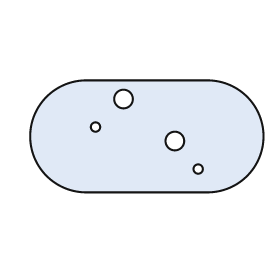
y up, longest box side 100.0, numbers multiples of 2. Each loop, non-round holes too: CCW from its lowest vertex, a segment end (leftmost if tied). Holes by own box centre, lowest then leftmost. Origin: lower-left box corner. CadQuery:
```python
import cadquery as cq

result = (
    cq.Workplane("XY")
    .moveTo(24.0, 0.0)
    .lineTo(76.0, 0.0)
    .threePointArc((100.0, 24.0), (76.0, 48.0))
    .lineTo(24.0, 48.0)
    .threePointArc((0.0, 24.0), (24.0, 0.0))
    .close()
    .moveTo(72.0, 10.0)
    .circle(2.0)
    .moveTo(62.0, 22.0)
    .circle(4.0)
    .moveTo(28.0, 28.0)
    .circle(2.0)
    .moveTo(40.0, 40.0)
    .circle(4.0)
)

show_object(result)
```